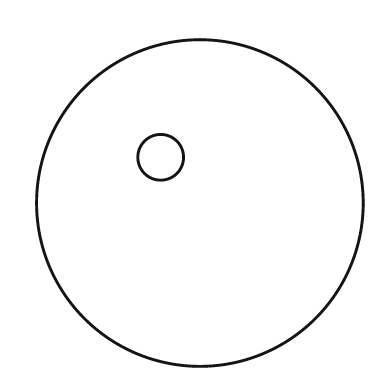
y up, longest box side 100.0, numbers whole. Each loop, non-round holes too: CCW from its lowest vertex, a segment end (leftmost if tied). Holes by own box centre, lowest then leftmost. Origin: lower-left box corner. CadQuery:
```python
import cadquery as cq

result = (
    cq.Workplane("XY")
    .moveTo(50.0, 50.0)
    .circle(50.0)
    .moveTo(38.0, 64.0)
    .circle(7.0)
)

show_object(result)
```